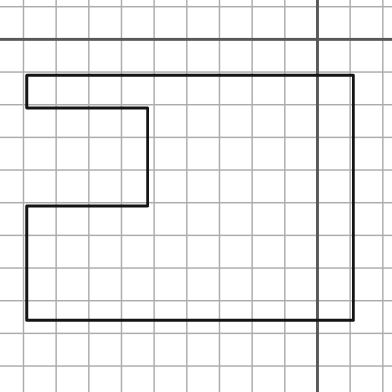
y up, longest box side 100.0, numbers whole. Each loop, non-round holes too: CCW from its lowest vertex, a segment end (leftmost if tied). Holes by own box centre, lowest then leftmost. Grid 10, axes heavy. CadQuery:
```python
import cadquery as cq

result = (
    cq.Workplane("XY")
    .moveTo(-89.0, -86.0)
    .lineTo(11.0, -86.0)
    .lineTo(11.0, -11.0)
    .lineTo(-89.0, -11.0)
    .lineTo(-89.0, -21.0)
    .lineTo(-52.0, -21.0)
    .lineTo(-52.0, -51.0)
    .lineTo(-89.0, -51.0)
    .close()
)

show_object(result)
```